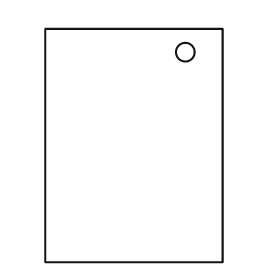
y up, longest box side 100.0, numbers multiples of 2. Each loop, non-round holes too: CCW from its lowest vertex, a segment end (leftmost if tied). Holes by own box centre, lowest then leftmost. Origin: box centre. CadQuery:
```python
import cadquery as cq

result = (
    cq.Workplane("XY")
    .moveTo(-38.0, -50.0)
    .lineTo(38.0, -50.0)
    .lineTo(38.0, 50.0)
    .lineTo(-38.0, 50.0)
    .close()
    .moveTo(22.0, 40.0)
    .circle(4.0)
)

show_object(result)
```